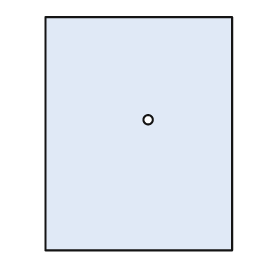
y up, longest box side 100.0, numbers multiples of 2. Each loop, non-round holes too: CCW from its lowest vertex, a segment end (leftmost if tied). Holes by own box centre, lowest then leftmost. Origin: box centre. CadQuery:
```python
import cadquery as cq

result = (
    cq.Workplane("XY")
    .moveTo(-40.0, -50.0)
    .lineTo(40.0, -50.0)
    .lineTo(40.0, 50.0)
    .lineTo(-40.0, 50.0)
    .close()
    .moveTo(4.0, 6.0)
    .circle(2.0)
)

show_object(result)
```